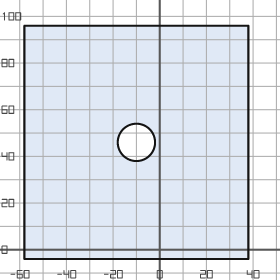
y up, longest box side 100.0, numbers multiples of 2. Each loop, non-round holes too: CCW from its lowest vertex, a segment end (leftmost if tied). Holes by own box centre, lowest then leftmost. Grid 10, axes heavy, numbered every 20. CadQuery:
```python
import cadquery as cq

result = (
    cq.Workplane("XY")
    .moveTo(-58.0, -4.0)
    .lineTo(38.0, -4.0)
    .lineTo(38.0, 96.0)
    .lineTo(-58.0, 96.0)
    .close()
    .moveTo(-10.0, 46.0)
    .circle(8.0)
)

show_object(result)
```